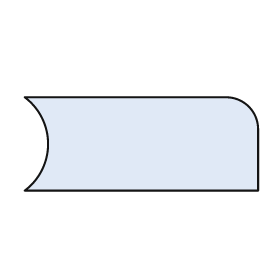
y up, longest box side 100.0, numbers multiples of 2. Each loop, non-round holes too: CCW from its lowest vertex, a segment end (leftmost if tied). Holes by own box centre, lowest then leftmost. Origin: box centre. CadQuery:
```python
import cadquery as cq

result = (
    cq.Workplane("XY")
    .moveTo(-50.0, -20.0)
    .lineTo(50.0, -20.0)
    .lineTo(50.0, 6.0)
    .threePointArc((46.0, 16.0), (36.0, 20.0))
    .lineTo(-50.0, 20.0)
    .threePointArc((-40.0, 0.0), (-50.0, -20.0))
    .close()
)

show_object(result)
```